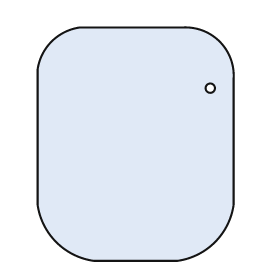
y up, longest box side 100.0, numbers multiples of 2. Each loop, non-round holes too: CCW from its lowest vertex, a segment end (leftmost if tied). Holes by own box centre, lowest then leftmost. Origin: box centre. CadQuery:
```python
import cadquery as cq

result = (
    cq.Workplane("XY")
    .moveTo(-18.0, -50.0)
    .lineTo(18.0, -50.0)
    .threePointArc((34.0, -42.0), (42.0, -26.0))
    .lineTo(42.0, 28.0)
    .threePointArc((36.0, 44.0), (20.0, 50.0))
    .lineTo(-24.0, 50.0)
    .threePointArc((-36.0, 44.0), (-42.0, 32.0))
    .lineTo(-42.0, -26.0)
    .threePointArc((-34.0, -42.0), (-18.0, -50.0))
    .close()
    .moveTo(32.0, 24.0)
    .circle(2.0)
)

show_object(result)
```